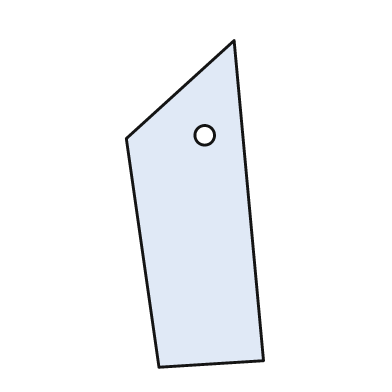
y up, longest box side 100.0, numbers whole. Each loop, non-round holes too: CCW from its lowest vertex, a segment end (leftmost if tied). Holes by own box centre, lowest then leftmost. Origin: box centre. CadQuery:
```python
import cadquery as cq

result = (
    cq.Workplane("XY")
    .moveTo(-11.0, -50.0)
    .lineTo(21.0, -48.0)
    .lineTo(12.0, 50.0)
    .lineTo(-21.0, 20.0)
    .close()
    .moveTo(3.0, 21.0)
    .circle(3.0)
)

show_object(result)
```